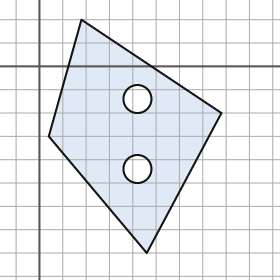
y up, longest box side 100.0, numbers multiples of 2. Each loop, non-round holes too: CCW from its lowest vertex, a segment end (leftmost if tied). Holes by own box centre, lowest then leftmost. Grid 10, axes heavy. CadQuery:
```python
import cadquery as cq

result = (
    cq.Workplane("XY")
    .moveTo(46.0, -80.0)
    .lineTo(78.0, -20.0)
    .lineTo(18.0, 20.0)
    .lineTo(4.0, -30.0)
    .close()
    .moveTo(42.0, -44.0)
    .circle(6.0)
    .moveTo(42.0, -14.0)
    .circle(6.0)
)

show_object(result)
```